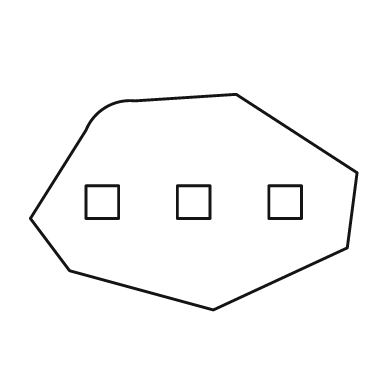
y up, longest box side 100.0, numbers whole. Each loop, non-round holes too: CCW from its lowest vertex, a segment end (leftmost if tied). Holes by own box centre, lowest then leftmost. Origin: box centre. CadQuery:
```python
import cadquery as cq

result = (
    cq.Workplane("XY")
    .moveTo(6.0, -33.0)
    .lineTo(47.0, -14.0)
    .lineTo(50.0, 9.0)
    .lineTo(13.0, 33.0)
    .lineTo(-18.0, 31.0)
    .threePointArc((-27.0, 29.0), (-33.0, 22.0))
    .lineTo(-50.0, -5.0)
    .lineTo(-38.0, -21.0)
    .close()
    .moveTo(-33.0, -5.0)
    .lineTo(-23.0, -5.0)
    .lineTo(-23.0, 5.0)
    .lineTo(-33.0, 5.0)
    .close()
    .moveTo(-5.0, -5.0)
    .lineTo(5.0, -5.0)
    .lineTo(5.0, 5.0)
    .lineTo(-5.0, 5.0)
    .close()
    .moveTo(23.0, -5.0)
    .lineTo(33.0, -5.0)
    .lineTo(33.0, 5.0)
    .lineTo(23.0, 5.0)
    .close()
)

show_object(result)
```